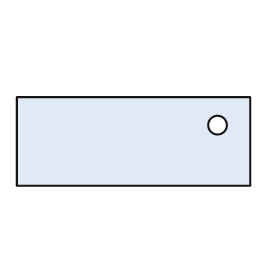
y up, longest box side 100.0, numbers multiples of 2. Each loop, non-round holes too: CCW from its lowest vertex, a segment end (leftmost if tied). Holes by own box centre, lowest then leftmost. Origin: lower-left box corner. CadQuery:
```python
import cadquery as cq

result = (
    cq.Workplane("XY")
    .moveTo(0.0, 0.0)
    .lineTo(100.0, 0.0)
    .lineTo(100.0, 38.0)
    .lineTo(0.0, 38.0)
    .close()
    .moveTo(86.0, 26.0)
    .circle(4.0)
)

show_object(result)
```